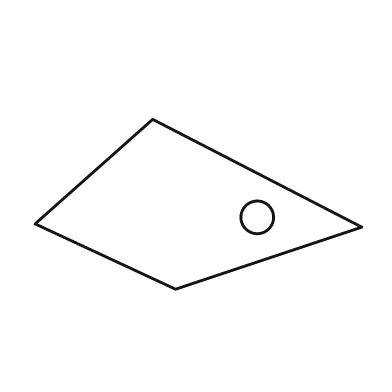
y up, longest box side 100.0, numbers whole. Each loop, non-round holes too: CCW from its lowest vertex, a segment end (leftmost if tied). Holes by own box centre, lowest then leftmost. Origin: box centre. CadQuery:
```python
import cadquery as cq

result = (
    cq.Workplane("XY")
    .moveTo(-7.0, -26.0)
    .lineTo(50.0, -7.0)
    .lineTo(-14.0, 26.0)
    .lineTo(-50.0, -6.0)
    .close()
    .moveTo(18.0, -4.0)
    .circle(5.0)
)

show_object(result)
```